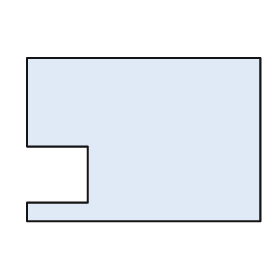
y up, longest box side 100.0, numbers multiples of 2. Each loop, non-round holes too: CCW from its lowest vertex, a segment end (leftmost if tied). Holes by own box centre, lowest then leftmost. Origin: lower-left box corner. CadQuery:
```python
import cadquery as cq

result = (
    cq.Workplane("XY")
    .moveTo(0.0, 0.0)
    .lineTo(100.0, 0.0)
    .lineTo(100.0, 70.0)
    .lineTo(0.0, 70.0)
    .lineTo(0.0, 32.0)
    .lineTo(26.0, 32.0)
    .lineTo(26.0, 8.0)
    .lineTo(0.0, 8.0)
    .close()
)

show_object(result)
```